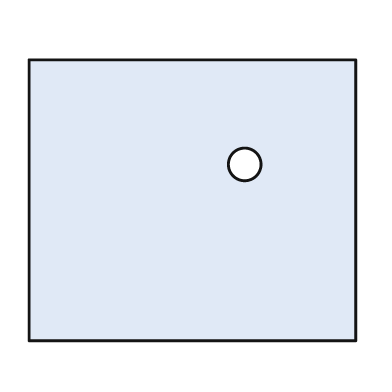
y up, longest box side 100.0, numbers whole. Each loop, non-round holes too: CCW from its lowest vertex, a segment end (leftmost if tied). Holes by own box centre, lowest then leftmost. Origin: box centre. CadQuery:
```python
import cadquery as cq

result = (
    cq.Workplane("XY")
    .moveTo(-50.0, -43.0)
    .lineTo(50.0, -43.0)
    .lineTo(50.0, 43.0)
    .lineTo(-50.0, 43.0)
    .close()
    .moveTo(16.0, 11.0)
    .circle(5.0)
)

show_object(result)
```